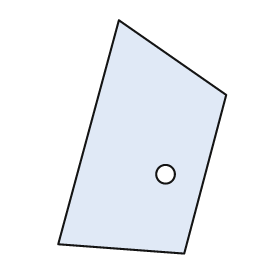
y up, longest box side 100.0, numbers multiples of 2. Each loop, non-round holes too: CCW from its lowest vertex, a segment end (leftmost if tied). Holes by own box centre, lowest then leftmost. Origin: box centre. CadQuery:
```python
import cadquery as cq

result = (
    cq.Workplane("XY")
    .moveTo(18.0, -50.0)
    .lineTo(36.0, 18.0)
    .lineTo(-10.0, 50.0)
    .lineTo(-36.0, -46.0)
    .close()
    .moveTo(10.0, -16.0)
    .circle(4.0)
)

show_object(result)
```